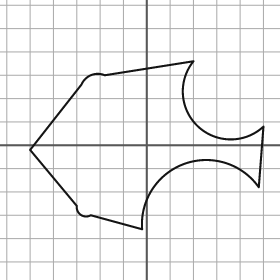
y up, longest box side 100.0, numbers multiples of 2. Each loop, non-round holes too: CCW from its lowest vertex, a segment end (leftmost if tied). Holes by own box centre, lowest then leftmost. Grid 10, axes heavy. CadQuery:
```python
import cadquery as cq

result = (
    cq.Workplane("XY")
    .moveTo(-2.0, -36.0)
    .threePointArc((16.0, -8.0), (48.0, -18.0))
    .lineTo(50.0, 8.0)
    .threePointArc((22.0, 8.0), (20.0, 36.0))
    .lineTo(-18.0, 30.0)
    .threePointArc((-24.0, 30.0), (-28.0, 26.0))
    .lineTo(-50.0, -2.0)
    .lineTo(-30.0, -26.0)
    .threePointArc((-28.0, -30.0), (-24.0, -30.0))
    .close()
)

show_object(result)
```